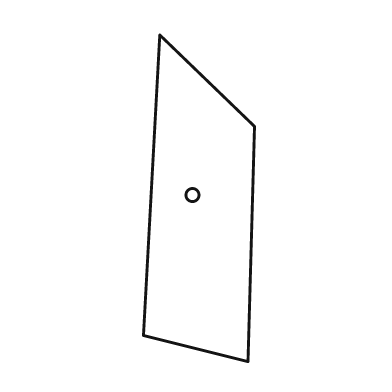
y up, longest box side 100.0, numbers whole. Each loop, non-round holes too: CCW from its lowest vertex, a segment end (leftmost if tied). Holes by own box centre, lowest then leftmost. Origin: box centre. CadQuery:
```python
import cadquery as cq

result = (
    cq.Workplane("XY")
    .moveTo(15.0, -50.0)
    .lineTo(17.0, 22.0)
    .lineTo(-12.0, 50.0)
    .lineTo(-17.0, -42.0)
    .close()
    .moveTo(-2.0, 1.0)
    .circle(2.0)
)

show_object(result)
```